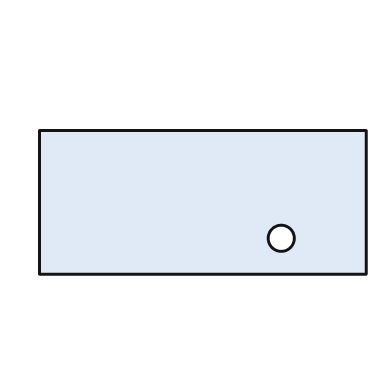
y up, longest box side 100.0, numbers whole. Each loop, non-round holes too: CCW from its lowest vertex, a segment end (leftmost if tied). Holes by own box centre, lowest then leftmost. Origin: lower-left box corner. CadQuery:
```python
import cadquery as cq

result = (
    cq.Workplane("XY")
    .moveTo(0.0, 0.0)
    .lineTo(100.0, 0.0)
    .lineTo(100.0, 44.0)
    .lineTo(0.0, 44.0)
    .close()
    .moveTo(74.0, 11.0)
    .circle(4.0)
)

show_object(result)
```